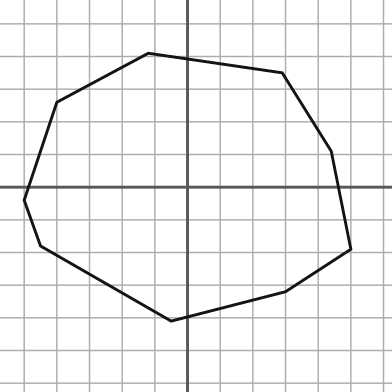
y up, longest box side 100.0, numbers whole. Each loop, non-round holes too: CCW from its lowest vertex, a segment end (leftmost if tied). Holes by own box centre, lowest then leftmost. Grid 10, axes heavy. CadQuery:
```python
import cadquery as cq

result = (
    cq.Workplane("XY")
    .moveTo(-5.0, -41.0)
    .lineTo(30.0, -32.0)
    .lineTo(50.0, -19.0)
    .lineTo(44.0, 11.0)
    .lineTo(29.0, 35.0)
    .lineTo(-12.0, 41.0)
    .lineTo(-40.0, 26.0)
    .lineTo(-50.0, -4.0)
    .lineTo(-45.0, -18.0)
    .close()
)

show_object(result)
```